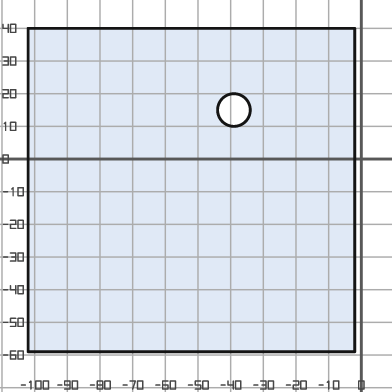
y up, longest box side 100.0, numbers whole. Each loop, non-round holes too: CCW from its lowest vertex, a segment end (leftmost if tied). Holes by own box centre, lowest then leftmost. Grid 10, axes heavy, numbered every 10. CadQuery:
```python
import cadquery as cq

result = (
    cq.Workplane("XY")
    .moveTo(-102.0, -59.0)
    .lineTo(-2.0, -59.0)
    .lineTo(-2.0, 40.0)
    .lineTo(-102.0, 40.0)
    .close()
    .moveTo(-39.0, 15.0)
    .circle(5.0)
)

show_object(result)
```